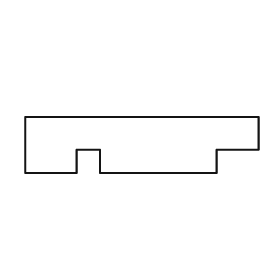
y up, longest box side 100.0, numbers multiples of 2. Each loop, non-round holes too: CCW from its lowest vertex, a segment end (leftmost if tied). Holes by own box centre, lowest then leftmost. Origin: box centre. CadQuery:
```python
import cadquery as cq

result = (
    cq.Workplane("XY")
    .moveTo(-50.0, -12.0)
    .lineTo(-28.0, -12.0)
    .lineTo(-28.0, -2.0)
    .lineTo(-18.0, -2.0)
    .lineTo(-18.0, -12.0)
    .lineTo(32.0, -12.0)
    .lineTo(32.0, -2.0)
    .lineTo(50.0, -2.0)
    .lineTo(50.0, 12.0)
    .lineTo(-50.0, 12.0)
    .close()
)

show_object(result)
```